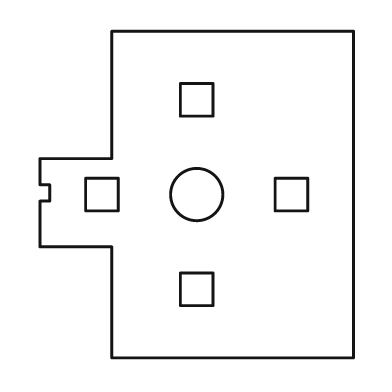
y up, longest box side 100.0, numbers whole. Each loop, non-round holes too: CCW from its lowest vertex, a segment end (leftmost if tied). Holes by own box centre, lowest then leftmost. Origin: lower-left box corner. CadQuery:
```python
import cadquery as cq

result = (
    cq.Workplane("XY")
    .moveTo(22.0, 0.0)
    .lineTo(96.0, 0.0)
    .lineTo(96.0, 100.0)
    .lineTo(22.0, 100.0)
    .lineTo(22.0, 61.0)
    .lineTo(0.0, 61.0)
    .lineTo(0.0, 53.0)
    .lineTo(3.0, 53.0)
    .lineTo(3.0, 48.0)
    .lineTo(0.0, 48.0)
    .lineTo(0.0, 34.0)
    .lineTo(22.0, 34.0)
    .close()
    .moveTo(43.0, 16.0)
    .lineTo(53.0, 16.0)
    .lineTo(53.0, 26.0)
    .lineTo(43.0, 26.0)
    .close()
    .moveTo(14.0, 45.0)
    .lineTo(24.0, 45.0)
    .lineTo(24.0, 55.0)
    .lineTo(14.0, 55.0)
    .close()
    .moveTo(48.0, 50.0)
    .circle(8.0)
    .moveTo(72.0, 45.0)
    .lineTo(82.0, 45.0)
    .lineTo(82.0, 55.0)
    .lineTo(72.0, 55.0)
    .close()
    .moveTo(43.0, 74.0)
    .lineTo(53.0, 74.0)
    .lineTo(53.0, 84.0)
    .lineTo(43.0, 84.0)
    .close()
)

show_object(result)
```